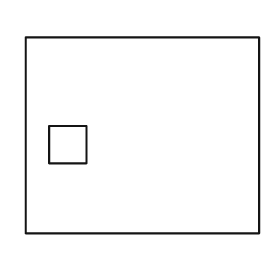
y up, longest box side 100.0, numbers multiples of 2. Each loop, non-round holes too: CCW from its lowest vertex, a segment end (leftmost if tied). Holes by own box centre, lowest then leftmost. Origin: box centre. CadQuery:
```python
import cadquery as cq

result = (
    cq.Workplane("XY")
    .moveTo(-50.0, -42.0)
    .lineTo(50.0, -42.0)
    .lineTo(50.0, 42.0)
    .lineTo(-50.0, 42.0)
    .close()
    .moveTo(-40.0, -12.0)
    .lineTo(-24.0, -12.0)
    .lineTo(-24.0, 4.0)
    .lineTo(-40.0, 4.0)
    .close()
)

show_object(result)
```